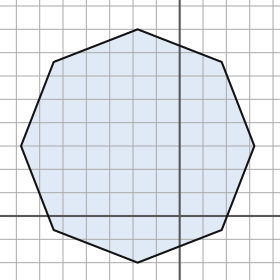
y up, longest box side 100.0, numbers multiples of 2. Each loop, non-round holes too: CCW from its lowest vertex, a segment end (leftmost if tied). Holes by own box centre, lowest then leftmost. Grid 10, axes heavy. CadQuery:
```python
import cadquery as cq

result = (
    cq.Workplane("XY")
    .moveTo(-18.0, -20.0)
    .lineTo(18.0, -6.0)
    .lineTo(32.0, 30.0)
    .lineTo(18.0, 66.0)
    .lineTo(-18.0, 80.0)
    .lineTo(-54.0, 66.0)
    .lineTo(-68.0, 30.0)
    .lineTo(-54.0, -6.0)
    .close()
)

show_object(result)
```